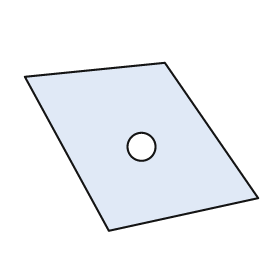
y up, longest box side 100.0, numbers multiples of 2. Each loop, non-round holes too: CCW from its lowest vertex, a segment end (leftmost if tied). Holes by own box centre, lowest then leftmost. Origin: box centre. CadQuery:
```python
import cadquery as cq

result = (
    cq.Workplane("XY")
    .moveTo(-14.0, -36.0)
    .lineTo(50.0, -22.0)
    .lineTo(10.0, 36.0)
    .lineTo(-50.0, 30.0)
    .close()
    .moveTo(0.0, 0.0)
    .circle(6.0)
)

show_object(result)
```